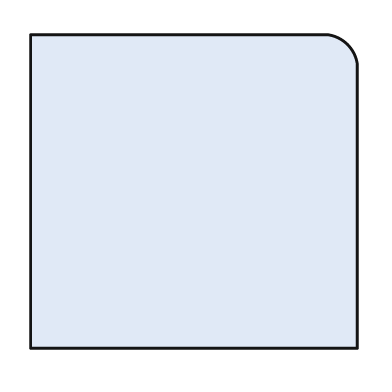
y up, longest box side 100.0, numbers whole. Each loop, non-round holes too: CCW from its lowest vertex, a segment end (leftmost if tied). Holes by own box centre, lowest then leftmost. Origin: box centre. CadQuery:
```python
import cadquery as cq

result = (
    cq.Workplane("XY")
    .moveTo(-50.0, -48.0)
    .lineTo(50.0, -48.0)
    .lineTo(50.0, 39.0)
    .threePointArc((47.0, 45.0), (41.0, 48.0))
    .lineTo(-50.0, 48.0)
    .close()
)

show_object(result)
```